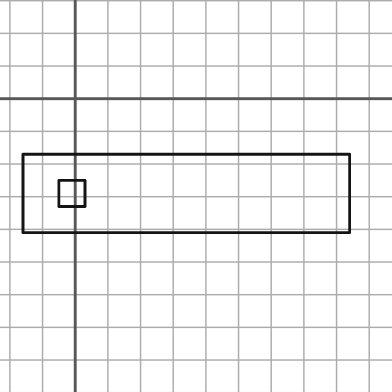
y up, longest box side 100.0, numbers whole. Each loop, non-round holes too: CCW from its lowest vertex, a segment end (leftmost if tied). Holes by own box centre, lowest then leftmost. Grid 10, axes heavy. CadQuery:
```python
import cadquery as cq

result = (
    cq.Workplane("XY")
    .moveTo(-16.0, -41.0)
    .lineTo(84.0, -41.0)
    .lineTo(84.0, -17.0)
    .lineTo(-16.0, -17.0)
    .close()
    .moveTo(-5.0, -33.0)
    .lineTo(3.0, -33.0)
    .lineTo(3.0, -25.0)
    .lineTo(-5.0, -25.0)
    .close()
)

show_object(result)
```